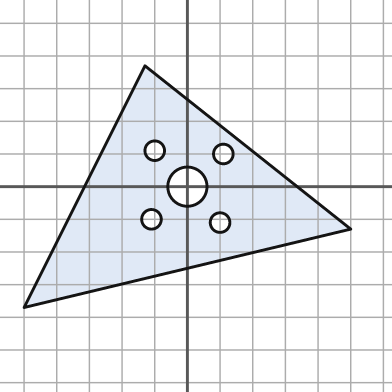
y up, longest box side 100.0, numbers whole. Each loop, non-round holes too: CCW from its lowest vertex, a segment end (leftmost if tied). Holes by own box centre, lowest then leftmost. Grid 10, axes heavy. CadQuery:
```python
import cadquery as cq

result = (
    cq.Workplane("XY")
    .moveTo(-50.0, -37.0)
    .lineTo(50.0, -13.0)
    .lineTo(-13.0, 37.0)
    .close()
    .moveTo(10.0, -11.0)
    .circle(3.0)
    .moveTo(-11.0, -10.0)
    .circle(3.0)
    .moveTo(0.0, 0.0)
    .circle(6.0)
    .moveTo(11.0, 10.0)
    .circle(3.0)
    .moveTo(-10.0, 11.0)
    .circle(3.0)
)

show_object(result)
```